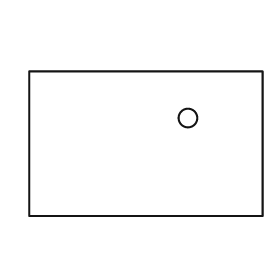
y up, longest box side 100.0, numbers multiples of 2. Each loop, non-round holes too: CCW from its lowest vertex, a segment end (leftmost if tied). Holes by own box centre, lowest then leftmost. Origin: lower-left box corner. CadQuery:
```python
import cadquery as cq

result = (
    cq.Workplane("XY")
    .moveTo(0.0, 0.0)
    .lineTo(100.0, 0.0)
    .lineTo(100.0, 62.0)
    .lineTo(0.0, 62.0)
    .close()
    .moveTo(68.0, 42.0)
    .circle(4.0)
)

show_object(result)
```